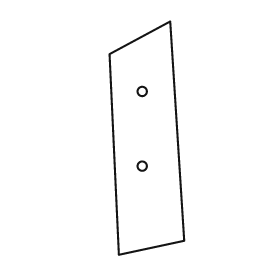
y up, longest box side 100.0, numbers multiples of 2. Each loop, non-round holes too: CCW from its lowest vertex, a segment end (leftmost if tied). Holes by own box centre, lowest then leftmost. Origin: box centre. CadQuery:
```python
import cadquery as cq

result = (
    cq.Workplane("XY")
    .moveTo(-12.0, -50.0)
    .lineTo(16.0, -44.0)
    .lineTo(10.0, 50.0)
    .lineTo(-16.0, 36.0)
    .close()
    .moveTo(-2.0, -12.0)
    .circle(2.0)
    .moveTo(-2.0, 20.0)
    .circle(2.0)
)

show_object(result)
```